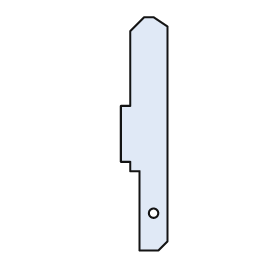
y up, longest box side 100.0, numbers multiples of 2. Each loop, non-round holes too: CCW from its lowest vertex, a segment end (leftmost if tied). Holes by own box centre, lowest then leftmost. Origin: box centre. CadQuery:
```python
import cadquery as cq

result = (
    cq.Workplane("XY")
    .moveTo(-2.0, -50.0)
    .lineTo(6.0, -50.0)
    .lineTo(10.0, -46.0)
    .lineTo(10.0, 46.0)
    .lineTo(4.0, 50.0)
    .lineTo(0.0, 50.0)
    .lineTo(-6.0, 44.0)
    .lineTo(-6.0, 12.0)
    .lineTo(-10.0, 12.0)
    .lineTo(-10.0, -12.0)
    .lineTo(-6.0, -12.0)
    .lineTo(-6.0, -16.0)
    .lineTo(-2.0, -16.0)
    .close()
    .moveTo(4.0, -34.0)
    .circle(2.0)
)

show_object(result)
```